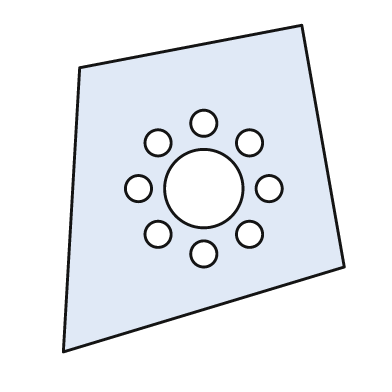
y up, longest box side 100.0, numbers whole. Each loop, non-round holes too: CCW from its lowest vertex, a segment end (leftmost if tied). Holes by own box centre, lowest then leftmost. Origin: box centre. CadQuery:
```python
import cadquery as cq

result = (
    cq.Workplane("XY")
    .moveTo(-43.0, -50.0)
    .lineTo(43.0, -24.0)
    .lineTo(30.0, 50.0)
    .lineTo(-38.0, 37.0)
    .close()
    .moveTo(0.0, -20.0)
    .circle(4.0)
    .moveTo(-14.0, -14.0)
    .circle(4.0)
    .moveTo(14.0, -14.0)
    .circle(4.0)
    .moveTo(-20.0, 0.0)
    .circle(4.0)
    .moveTo(0.0, 0.0)
    .circle(12.0)
    .moveTo(20.0, 0.0)
    .circle(4.0)
    .moveTo(-14.0, 14.0)
    .circle(4.0)
    .moveTo(14.0, 14.0)
    .circle(4.0)
    .moveTo(0.0, 20.0)
    .circle(4.0)
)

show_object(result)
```